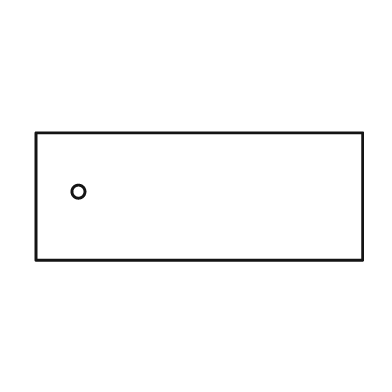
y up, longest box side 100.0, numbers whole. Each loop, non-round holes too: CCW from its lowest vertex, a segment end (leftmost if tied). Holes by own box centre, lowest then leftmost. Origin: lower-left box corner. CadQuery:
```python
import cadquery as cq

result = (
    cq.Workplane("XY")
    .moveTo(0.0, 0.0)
    .lineTo(100.0, 0.0)
    .lineTo(100.0, 39.0)
    .lineTo(0.0, 39.0)
    .close()
    .moveTo(13.0, 21.0)
    .circle(2.0)
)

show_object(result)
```